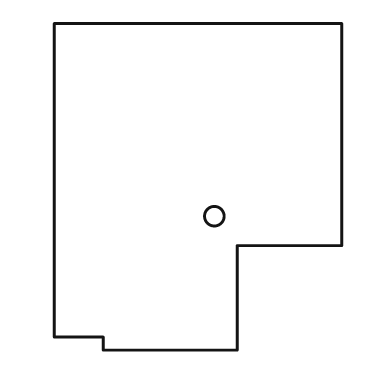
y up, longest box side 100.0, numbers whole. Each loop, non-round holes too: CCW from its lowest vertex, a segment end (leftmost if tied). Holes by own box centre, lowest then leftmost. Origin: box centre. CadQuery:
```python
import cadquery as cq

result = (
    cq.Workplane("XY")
    .moveTo(-29.0, -50.0)
    .lineTo(12.0, -50.0)
    .lineTo(12.0, -18.0)
    .lineTo(44.0, -18.0)
    .lineTo(44.0, 50.0)
    .lineTo(-44.0, 50.0)
    .lineTo(-44.0, -46.0)
    .lineTo(-29.0, -46.0)
    .close()
    .moveTo(5.0, -9.0)
    .circle(3.0)
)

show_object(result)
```